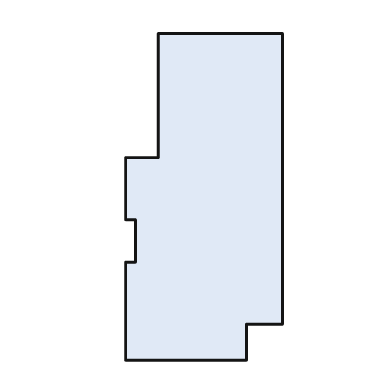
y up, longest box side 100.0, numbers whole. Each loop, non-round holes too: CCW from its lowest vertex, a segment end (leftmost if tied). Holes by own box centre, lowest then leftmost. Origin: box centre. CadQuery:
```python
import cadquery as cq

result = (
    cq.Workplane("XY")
    .moveTo(-24.0, -50.0)
    .lineTo(13.0, -50.0)
    .lineTo(13.0, -39.0)
    .lineTo(24.0, -39.0)
    .lineTo(24.0, 50.0)
    .lineTo(-14.0, 50.0)
    .lineTo(-14.0, 12.0)
    .lineTo(-24.0, 12.0)
    .lineTo(-24.0, -7.0)
    .lineTo(-21.0, -7.0)
    .lineTo(-21.0, -20.0)
    .lineTo(-24.0, -20.0)
    .close()
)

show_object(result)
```